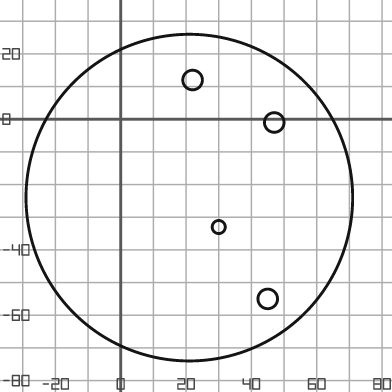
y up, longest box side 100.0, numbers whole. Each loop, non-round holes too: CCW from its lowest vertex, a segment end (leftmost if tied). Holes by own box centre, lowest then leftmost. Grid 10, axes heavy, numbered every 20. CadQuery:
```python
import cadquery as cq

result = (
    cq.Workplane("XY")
    .moveTo(21.0, -24.0)
    .circle(50.0)
    .moveTo(45.0, -55.0)
    .circle(3.0)
    .moveTo(30.0, -33.0)
    .circle(2.0)
    .moveTo(47.0, -1.0)
    .circle(3.0)
    .moveTo(22.0, 12.0)
    .circle(3.0)
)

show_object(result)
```